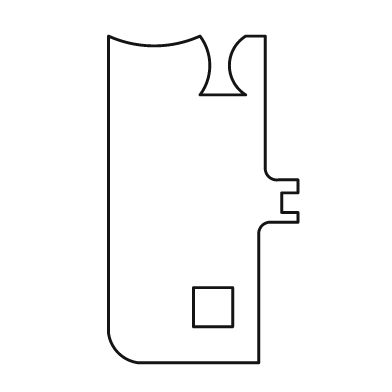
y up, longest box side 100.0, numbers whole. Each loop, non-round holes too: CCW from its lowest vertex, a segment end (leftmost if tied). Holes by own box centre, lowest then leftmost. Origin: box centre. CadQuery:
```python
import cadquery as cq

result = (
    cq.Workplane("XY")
    .moveTo(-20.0, -50.0)
    .lineTo(17.0, -50.0)
    .lineTo(17.0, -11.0)
    .threePointArc((18.0, -8.0), (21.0, -7.0))
    .lineTo(29.0, -7.0)
    .lineTo(29.0, -4.0)
    .lineTo(24.0, -4.0)
    .lineTo(24.0, 2.0)
    .lineTo(29.0, 2.0)
    .lineTo(29.0, 6.0)
    .lineTo(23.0, 6.0)
    .threePointArc((20.0, 7.0), (19.0, 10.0))
    .lineTo(19.0, 50.0)
    .lineTo(13.0, 50.0)
    .threePointArc((8.0, 41.0), (13.0, 32.0))
    .lineTo(-1.0, 32.0)
    .threePointArc((2.0, 41.0), (-1.0, 50.0))
    .threePointArc((-15.0, 47.0), (-29.0, 50.0))
    .lineTo(-29.0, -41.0)
    .threePointArc((-26.0, -47.0), (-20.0, -50.0))
    .close()
    .moveTo(-3.0, -39.0)
    .lineTo(9.0, -39.0)
    .lineTo(9.0, -27.0)
    .lineTo(-3.0, -27.0)
    .close()
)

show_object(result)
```